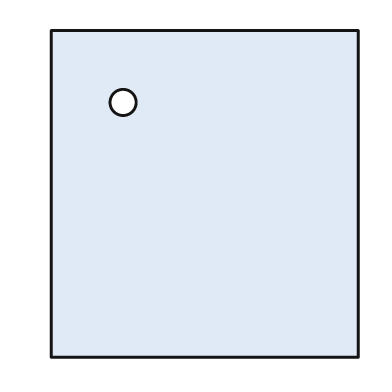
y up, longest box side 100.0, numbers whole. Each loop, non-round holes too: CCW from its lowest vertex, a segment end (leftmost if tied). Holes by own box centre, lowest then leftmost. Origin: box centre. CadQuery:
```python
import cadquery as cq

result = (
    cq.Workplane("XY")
    .moveTo(-47.0, -50.0)
    .lineTo(47.0, -50.0)
    .lineTo(47.0, 50.0)
    .lineTo(-47.0, 50.0)
    .close()
    .moveTo(-25.0, 28.0)
    .circle(4.0)
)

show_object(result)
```